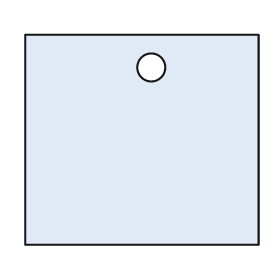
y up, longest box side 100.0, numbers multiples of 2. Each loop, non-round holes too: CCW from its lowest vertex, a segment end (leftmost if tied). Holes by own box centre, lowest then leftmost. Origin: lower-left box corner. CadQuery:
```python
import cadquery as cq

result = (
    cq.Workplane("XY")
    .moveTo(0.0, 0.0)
    .lineTo(100.0, 0.0)
    .lineTo(100.0, 90.0)
    .lineTo(0.0, 90.0)
    .close()
    .moveTo(54.0, 76.0)
    .circle(6.0)
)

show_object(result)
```